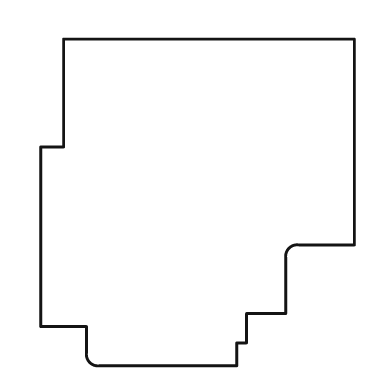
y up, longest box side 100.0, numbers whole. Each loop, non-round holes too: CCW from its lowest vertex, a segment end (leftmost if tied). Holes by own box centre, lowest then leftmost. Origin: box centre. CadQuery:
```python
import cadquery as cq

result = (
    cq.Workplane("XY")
    .moveTo(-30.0, -50.0)
    .lineTo(12.0, -50.0)
    .lineTo(12.0, -43.0)
    .lineTo(15.0, -43.0)
    .lineTo(15.0, -34.0)
    .lineTo(27.0, -34.0)
    .lineTo(27.0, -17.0)
    .threePointArc((28.0, -14.0), (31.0, -13.0))
    .lineTo(48.0, -13.0)
    .lineTo(48.0, 50.0)
    .lineTo(-41.0, 50.0)
    .lineTo(-41.0, 17.0)
    .lineTo(-48.0, 17.0)
    .lineTo(-48.0, -38.0)
    .lineTo(-34.0, -38.0)
    .lineTo(-34.0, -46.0)
    .threePointArc((-33.0, -49.0), (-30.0, -50.0))
    .close()
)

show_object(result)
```